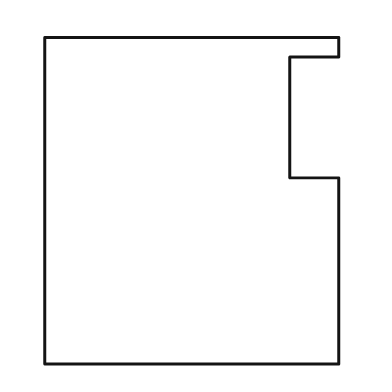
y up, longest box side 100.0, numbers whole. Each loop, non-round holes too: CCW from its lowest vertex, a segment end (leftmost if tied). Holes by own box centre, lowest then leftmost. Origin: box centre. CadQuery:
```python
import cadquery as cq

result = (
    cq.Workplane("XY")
    .moveTo(-45.0, -50.0)
    .lineTo(45.0, -50.0)
    .lineTo(45.0, 7.0)
    .lineTo(30.0, 7.0)
    .lineTo(30.0, 44.0)
    .lineTo(45.0, 44.0)
    .lineTo(45.0, 50.0)
    .lineTo(-45.0, 50.0)
    .close()
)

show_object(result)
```